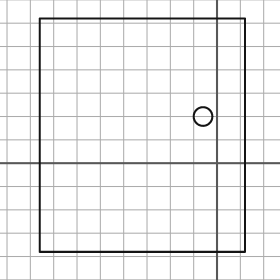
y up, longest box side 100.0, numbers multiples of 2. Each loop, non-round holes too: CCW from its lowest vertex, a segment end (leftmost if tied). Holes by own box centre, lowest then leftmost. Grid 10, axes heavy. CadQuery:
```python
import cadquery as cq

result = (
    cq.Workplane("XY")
    .moveTo(-76.0, -38.0)
    .lineTo(12.0, -38.0)
    .lineTo(12.0, 62.0)
    .lineTo(-76.0, 62.0)
    .close()
    .moveTo(-6.0, 20.0)
    .circle(4.0)
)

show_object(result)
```